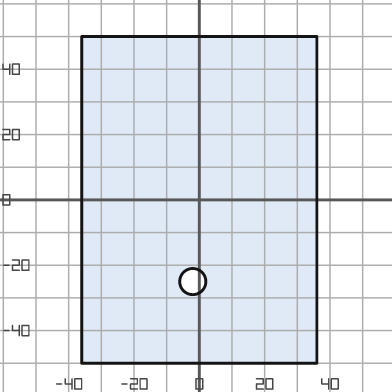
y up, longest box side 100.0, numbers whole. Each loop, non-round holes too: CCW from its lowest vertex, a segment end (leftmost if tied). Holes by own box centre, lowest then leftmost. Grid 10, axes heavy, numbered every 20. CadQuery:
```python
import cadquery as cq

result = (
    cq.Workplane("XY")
    .moveTo(-36.0, -50.0)
    .lineTo(36.0, -50.0)
    .lineTo(36.0, 50.0)
    .lineTo(-36.0, 50.0)
    .close()
    .moveTo(-2.0, -25.0)
    .circle(4.0)
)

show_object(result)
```